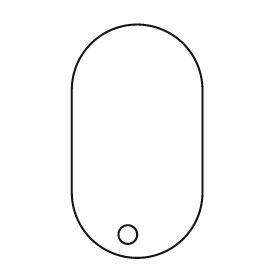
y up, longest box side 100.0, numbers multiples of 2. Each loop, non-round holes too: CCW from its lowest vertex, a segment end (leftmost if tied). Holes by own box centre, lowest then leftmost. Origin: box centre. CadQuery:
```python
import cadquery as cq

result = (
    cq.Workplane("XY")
    .moveTo(-28.0, -22.0)
    .threePointArc((0.0, -50.0), (28.0, -22.0))
    .lineTo(28.0, 22.0)
    .threePointArc((0.0, 50.0), (-28.0, 22.0))
    .close()
    .moveTo(-4.0, -40.0)
    .circle(4.0)
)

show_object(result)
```